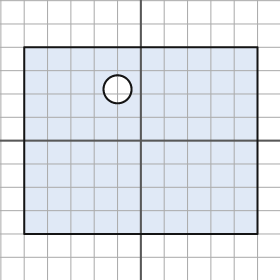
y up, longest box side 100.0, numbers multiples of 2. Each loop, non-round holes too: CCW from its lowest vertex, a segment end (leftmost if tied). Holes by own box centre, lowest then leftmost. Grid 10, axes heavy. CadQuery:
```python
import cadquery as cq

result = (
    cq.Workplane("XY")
    .moveTo(-50.0, -40.0)
    .lineTo(50.0, -40.0)
    .lineTo(50.0, 40.0)
    .lineTo(-50.0, 40.0)
    .close()
    .moveTo(-10.0, 22.0)
    .circle(6.0)
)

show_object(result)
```